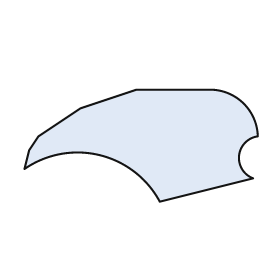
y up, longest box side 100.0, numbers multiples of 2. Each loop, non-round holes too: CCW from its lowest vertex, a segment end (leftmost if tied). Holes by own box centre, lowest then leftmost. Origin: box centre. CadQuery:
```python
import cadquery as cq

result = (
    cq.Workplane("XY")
    .moveTo(8.0, -24.0)
    .lineTo(48.0, -14.0)
    .threePointArc((42.0, -4.0), (50.0, 4.0))
    .threePointArc((44.0, 18.0), (30.0, 24.0))
    .lineTo(-2.0, 24.0)
    .lineTo(-26.0, 16.0)
    .lineTo(-44.0, 4.0)
    .lineTo(-48.0, -2.0)
    .lineTo(-50.0, -10.0)
    .threePointArc((-18.0, -4.0), (8.0, -24.0))
    .close()
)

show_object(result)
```